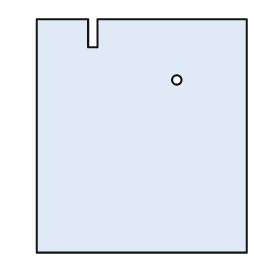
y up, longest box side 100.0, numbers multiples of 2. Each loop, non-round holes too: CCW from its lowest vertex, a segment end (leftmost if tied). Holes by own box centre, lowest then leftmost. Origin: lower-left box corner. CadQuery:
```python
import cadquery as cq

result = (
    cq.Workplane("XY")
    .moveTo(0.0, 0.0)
    .lineTo(90.0, 0.0)
    .lineTo(90.0, 100.0)
    .lineTo(26.0, 100.0)
    .lineTo(26.0, 88.0)
    .lineTo(22.0, 88.0)
    .lineTo(22.0, 100.0)
    .lineTo(0.0, 100.0)
    .close()
    .moveTo(60.0, 74.0)
    .circle(2.0)
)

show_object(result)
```